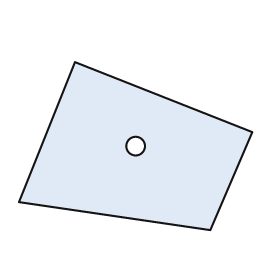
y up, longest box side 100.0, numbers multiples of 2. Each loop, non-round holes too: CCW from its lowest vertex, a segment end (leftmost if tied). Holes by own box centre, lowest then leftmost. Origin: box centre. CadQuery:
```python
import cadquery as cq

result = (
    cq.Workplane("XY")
    .moveTo(32.0, -36.0)
    .lineTo(50.0, 6.0)
    .lineTo(-26.0, 36.0)
    .lineTo(-50.0, -24.0)
    .close()
    .moveTo(0.0, 0.0)
    .circle(4.0)
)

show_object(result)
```